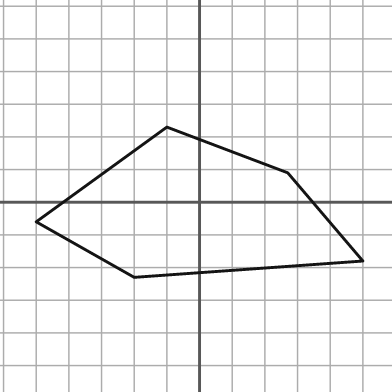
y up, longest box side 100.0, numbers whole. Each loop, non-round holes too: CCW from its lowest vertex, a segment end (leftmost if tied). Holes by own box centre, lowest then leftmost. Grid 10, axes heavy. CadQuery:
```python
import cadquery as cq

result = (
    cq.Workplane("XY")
    .moveTo(-20.0, -23.0)
    .lineTo(50.0, -18.0)
    .lineTo(27.0, 9.0)
    .lineTo(-10.0, 23.0)
    .lineTo(-50.0, -6.0)
    .close()
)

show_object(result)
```